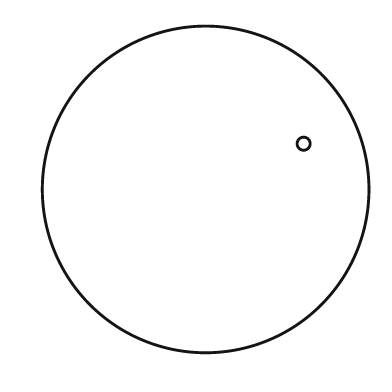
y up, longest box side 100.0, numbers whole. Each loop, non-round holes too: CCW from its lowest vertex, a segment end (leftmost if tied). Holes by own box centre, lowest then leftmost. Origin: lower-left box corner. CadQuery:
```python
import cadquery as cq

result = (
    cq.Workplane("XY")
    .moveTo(50.0, 50.0)
    .circle(50.0)
    .moveTo(80.0, 64.0)
    .circle(2.0)
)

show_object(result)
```